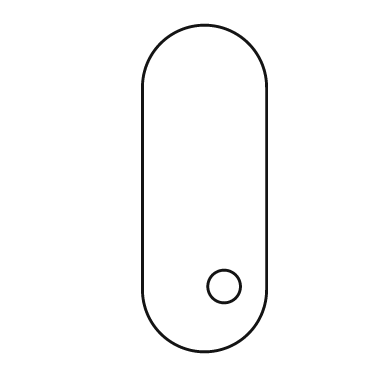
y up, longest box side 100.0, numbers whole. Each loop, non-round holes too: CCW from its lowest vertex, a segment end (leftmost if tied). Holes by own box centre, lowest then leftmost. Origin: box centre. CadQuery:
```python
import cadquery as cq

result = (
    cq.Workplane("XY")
    .moveTo(-19.0, -31.0)
    .threePointArc((0.0, -50.0), (19.0, -31.0))
    .lineTo(19.0, 31.0)
    .threePointArc((0.0, 50.0), (-19.0, 31.0))
    .close()
    .moveTo(6.0, -30.0)
    .circle(5.0)
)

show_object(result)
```